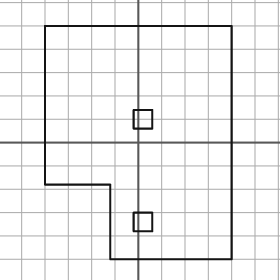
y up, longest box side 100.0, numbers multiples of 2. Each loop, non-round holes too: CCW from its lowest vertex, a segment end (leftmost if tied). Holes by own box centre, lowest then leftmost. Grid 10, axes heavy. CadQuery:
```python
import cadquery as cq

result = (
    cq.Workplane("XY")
    .moveTo(-12.0, -50.0)
    .lineTo(40.0, -50.0)
    .lineTo(40.0, 50.0)
    .lineTo(-40.0, 50.0)
    .lineTo(-40.0, -18.0)
    .lineTo(-12.0, -18.0)
    .close()
    .moveTo(-2.0, -38.0)
    .lineTo(6.0, -38.0)
    .lineTo(6.0, -30.0)
    .lineTo(-2.0, -30.0)
    .close()
    .moveTo(-2.0, 6.0)
    .lineTo(6.0, 6.0)
    .lineTo(6.0, 14.0)
    .lineTo(-2.0, 14.0)
    .close()
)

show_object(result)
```